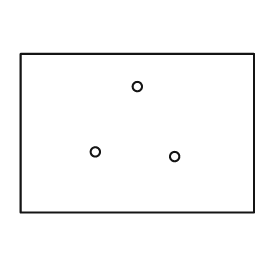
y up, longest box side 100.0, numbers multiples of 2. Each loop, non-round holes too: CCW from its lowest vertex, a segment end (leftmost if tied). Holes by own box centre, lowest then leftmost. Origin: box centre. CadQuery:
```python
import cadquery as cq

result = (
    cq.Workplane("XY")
    .moveTo(-50.0, -34.0)
    .lineTo(50.0, -34.0)
    .lineTo(50.0, 34.0)
    .lineTo(-50.0, 34.0)
    .close()
    .moveTo(16.0, -10.0)
    .circle(2.0)
    .moveTo(-18.0, -8.0)
    .circle(2.0)
    .moveTo(0.0, 20.0)
    .circle(2.0)
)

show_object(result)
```